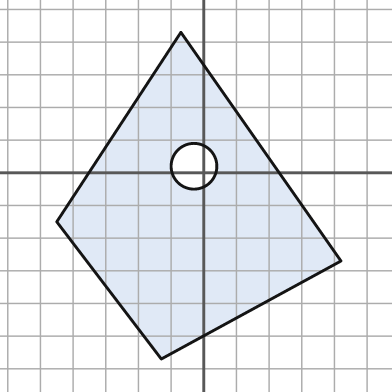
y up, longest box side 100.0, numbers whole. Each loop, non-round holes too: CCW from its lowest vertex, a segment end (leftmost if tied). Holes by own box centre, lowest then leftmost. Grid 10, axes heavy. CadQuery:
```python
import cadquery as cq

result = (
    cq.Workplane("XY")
    .moveTo(-13.0, -57.0)
    .lineTo(42.0, -27.0)
    .lineTo(-7.0, 43.0)
    .lineTo(-45.0, -15.0)
    .close()
    .moveTo(-3.0, 2.0)
    .circle(7.0)
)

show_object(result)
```